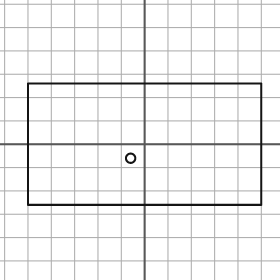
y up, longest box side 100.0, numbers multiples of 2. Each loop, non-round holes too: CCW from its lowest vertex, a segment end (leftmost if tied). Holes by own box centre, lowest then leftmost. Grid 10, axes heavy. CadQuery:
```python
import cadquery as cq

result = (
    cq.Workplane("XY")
    .moveTo(-50.0, -26.0)
    .lineTo(50.0, -26.0)
    .lineTo(50.0, 26.0)
    .lineTo(-50.0, 26.0)
    .close()
    .moveTo(-6.0, -6.0)
    .circle(2.0)
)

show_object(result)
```